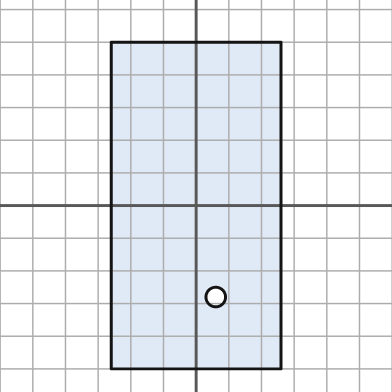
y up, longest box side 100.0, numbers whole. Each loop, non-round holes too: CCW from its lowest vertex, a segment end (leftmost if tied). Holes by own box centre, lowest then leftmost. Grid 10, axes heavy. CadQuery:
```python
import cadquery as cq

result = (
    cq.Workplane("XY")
    .moveTo(-26.0, -50.0)
    .lineTo(26.0, -50.0)
    .lineTo(26.0, 50.0)
    .lineTo(-26.0, 50.0)
    .close()
    .moveTo(6.0, -28.0)
    .circle(3.0)
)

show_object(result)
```